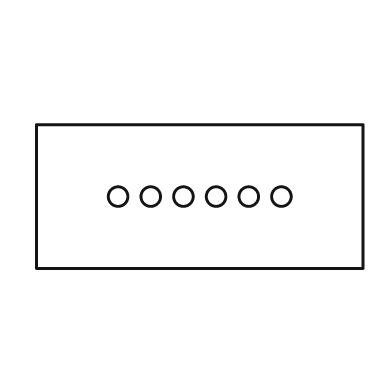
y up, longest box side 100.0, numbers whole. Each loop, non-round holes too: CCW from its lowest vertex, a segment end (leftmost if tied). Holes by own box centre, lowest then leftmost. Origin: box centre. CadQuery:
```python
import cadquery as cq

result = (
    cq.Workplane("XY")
    .moveTo(-50.0, -22.0)
    .lineTo(50.0, -22.0)
    .lineTo(50.0, 22.0)
    .lineTo(-50.0, 22.0)
    .close()
    .moveTo(-25.0, 0.0)
    .circle(3.0)
    .moveTo(-15.0, 0.0)
    .circle(3.0)
    .moveTo(-5.0, 0.0)
    .circle(3.0)
    .moveTo(5.0, 0.0)
    .circle(3.0)
    .moveTo(15.0, 0.0)
    .circle(3.0)
    .moveTo(25.0, 0.0)
    .circle(3.0)
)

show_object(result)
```